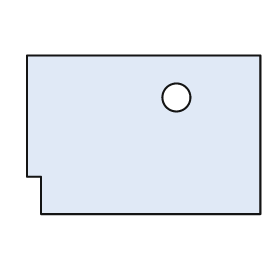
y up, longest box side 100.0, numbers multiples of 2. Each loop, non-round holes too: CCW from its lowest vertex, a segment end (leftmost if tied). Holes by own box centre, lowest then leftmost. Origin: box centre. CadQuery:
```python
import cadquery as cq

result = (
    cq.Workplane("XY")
    .moveTo(-44.0, -34.0)
    .lineTo(50.0, -34.0)
    .lineTo(50.0, 34.0)
    .lineTo(-50.0, 34.0)
    .lineTo(-50.0, -18.0)
    .lineTo(-44.0, -18.0)
    .close()
    .moveTo(14.0, 16.0)
    .circle(6.0)
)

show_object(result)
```